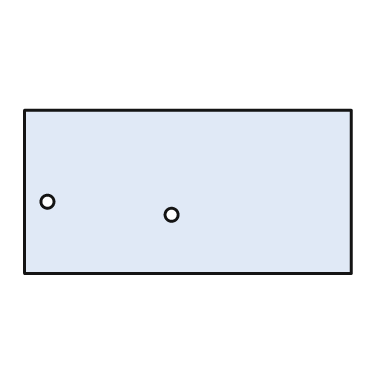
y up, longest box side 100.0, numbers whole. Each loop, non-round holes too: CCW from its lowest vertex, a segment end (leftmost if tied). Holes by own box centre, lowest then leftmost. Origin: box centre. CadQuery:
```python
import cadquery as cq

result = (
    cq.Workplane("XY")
    .moveTo(-50.0, -25.0)
    .lineTo(50.0, -25.0)
    .lineTo(50.0, 25.0)
    .lineTo(-50.0, 25.0)
    .close()
    .moveTo(-5.0, -7.0)
    .circle(2.0)
    .moveTo(-43.0, -3.0)
    .circle(2.0)
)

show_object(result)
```